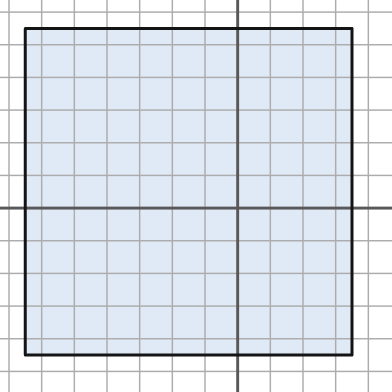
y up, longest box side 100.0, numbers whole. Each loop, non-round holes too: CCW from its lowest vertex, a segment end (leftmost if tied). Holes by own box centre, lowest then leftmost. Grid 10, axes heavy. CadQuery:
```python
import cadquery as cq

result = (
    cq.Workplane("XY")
    .moveTo(-65.0, -45.0)
    .lineTo(35.0, -45.0)
    .lineTo(35.0, 55.0)
    .lineTo(-65.0, 55.0)
    .close()
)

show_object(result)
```